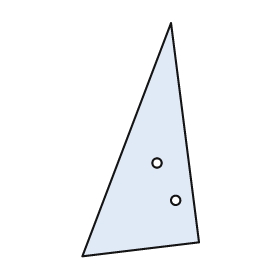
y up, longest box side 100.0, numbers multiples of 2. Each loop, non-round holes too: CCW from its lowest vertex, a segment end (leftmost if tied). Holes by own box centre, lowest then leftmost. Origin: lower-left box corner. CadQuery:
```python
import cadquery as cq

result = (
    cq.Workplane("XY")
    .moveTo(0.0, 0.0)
    .lineTo(50.0, 6.0)
    .lineTo(38.0, 100.0)
    .close()
    .moveTo(40.0, 24.0)
    .circle(2.0)
    .moveTo(32.0, 40.0)
    .circle(2.0)
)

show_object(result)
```